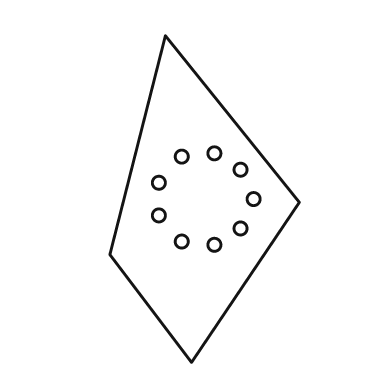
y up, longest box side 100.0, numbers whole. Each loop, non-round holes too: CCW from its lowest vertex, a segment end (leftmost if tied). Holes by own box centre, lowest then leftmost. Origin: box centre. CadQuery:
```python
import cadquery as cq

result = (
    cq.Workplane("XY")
    .moveTo(-4.0, -50.0)
    .lineTo(29.0, -1.0)
    .lineTo(-12.0, 50.0)
    .lineTo(-29.0, -17.0)
    .close()
    .moveTo(3.0, -14.0)
    .circle(2.0)
    .moveTo(-7.0, -13.0)
    .circle(2.0)
    .moveTo(11.0, -9.0)
    .circle(2.0)
    .moveTo(-14.0, -5.0)
    .circle(2.0)
    .moveTo(15.0, 0.0)
    .circle(2.0)
    .moveTo(-14.0, 5.0)
    .circle(2.0)
    .moveTo(11.0, 9.0)
    .circle(2.0)
    .moveTo(-7.0, 13.0)
    .circle(2.0)
    .moveTo(3.0, 14.0)
    .circle(2.0)
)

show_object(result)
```